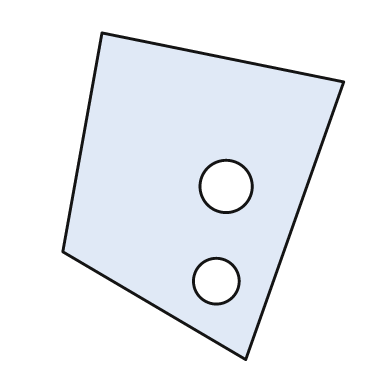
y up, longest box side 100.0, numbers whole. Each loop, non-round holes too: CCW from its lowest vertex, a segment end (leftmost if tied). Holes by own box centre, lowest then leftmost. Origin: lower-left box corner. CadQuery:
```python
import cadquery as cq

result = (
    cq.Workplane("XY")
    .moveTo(56.0, 0.0)
    .lineTo(86.0, 85.0)
    .lineTo(12.0, 100.0)
    .lineTo(0.0, 33.0)
    .close()
    .moveTo(47.0, 24.0)
    .circle(7.0)
    .moveTo(50.0, 53.0)
    .circle(8.0)
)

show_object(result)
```